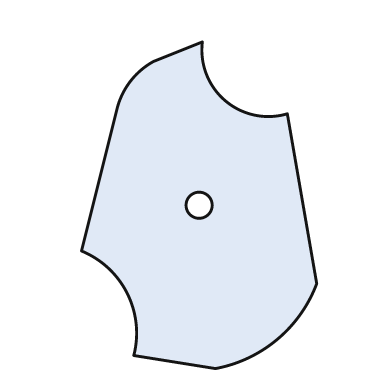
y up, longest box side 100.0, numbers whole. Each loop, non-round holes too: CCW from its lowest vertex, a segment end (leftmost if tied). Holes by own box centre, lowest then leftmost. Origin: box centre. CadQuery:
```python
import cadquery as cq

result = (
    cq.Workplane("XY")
    .moveTo(5.0, -50.0)
    .threePointArc((24.0, -41.0), (36.0, -24.0))
    .lineTo(27.0, 28.0)
    .threePointArc((8.0, 32.0), (1.0, 50.0))
    .lineTo(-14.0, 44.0)
    .threePointArc((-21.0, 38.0), (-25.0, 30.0))
    .lineTo(-36.0, -14.0)
    .threePointArc((-22.0, -27.0), (-20.0, -46.0))
    .close()
    .moveTo(0.0, 0.0)
    .circle(4.0)
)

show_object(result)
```